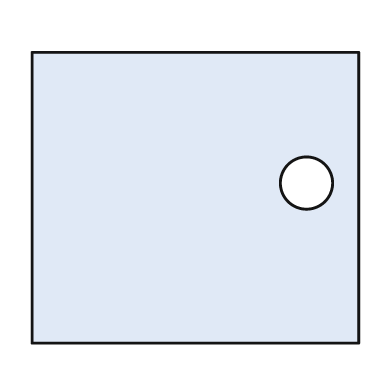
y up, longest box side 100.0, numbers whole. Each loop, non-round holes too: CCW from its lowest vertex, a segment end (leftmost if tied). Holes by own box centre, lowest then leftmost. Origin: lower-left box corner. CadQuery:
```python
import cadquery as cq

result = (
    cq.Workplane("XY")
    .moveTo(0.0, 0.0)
    .lineTo(100.0, 0.0)
    .lineTo(100.0, 89.0)
    .lineTo(0.0, 89.0)
    .close()
    .moveTo(84.0, 49.0)
    .circle(8.0)
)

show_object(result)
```